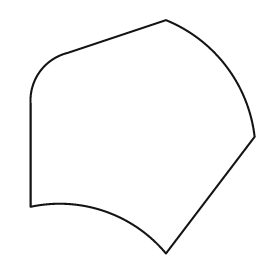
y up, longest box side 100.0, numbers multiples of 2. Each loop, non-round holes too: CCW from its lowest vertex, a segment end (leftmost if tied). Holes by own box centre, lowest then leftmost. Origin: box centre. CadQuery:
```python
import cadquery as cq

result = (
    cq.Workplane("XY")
    .moveTo(10.0, -50.0)
    .lineTo(48.0, 0.0)
    .threePointArc((36.0, 30.0), (10.0, 50.0))
    .lineTo(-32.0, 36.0)
    .threePointArc((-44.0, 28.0), (-48.0, 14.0))
    .lineTo(-48.0, -30.0)
    .threePointArc((-16.0, -32.0), (10.0, -50.0))
    .close()
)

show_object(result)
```